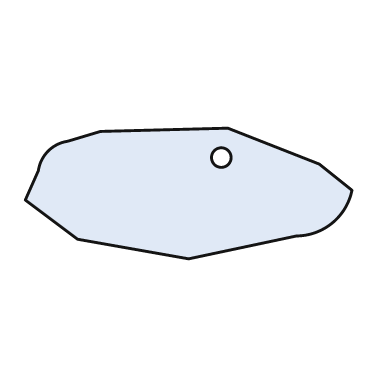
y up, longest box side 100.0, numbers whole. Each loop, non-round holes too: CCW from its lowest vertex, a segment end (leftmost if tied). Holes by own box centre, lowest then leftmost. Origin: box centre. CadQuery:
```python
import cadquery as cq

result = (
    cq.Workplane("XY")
    .moveTo(0.0, -20.0)
    .lineTo(33.0, -13.0)
    .threePointArc((44.0, -9.0), (50.0, 1.0))
    .lineTo(40.0, 9.0)
    .lineTo(12.0, 20.0)
    .lineTo(-27.0, 19.0)
    .lineTo(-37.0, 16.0)
    .threePointArc((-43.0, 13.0), (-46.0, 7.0))
    .lineTo(-50.0, -2.0)
    .lineTo(-34.0, -14.0)
    .close()
    .moveTo(10.0, 11.0)
    .circle(3.0)
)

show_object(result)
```